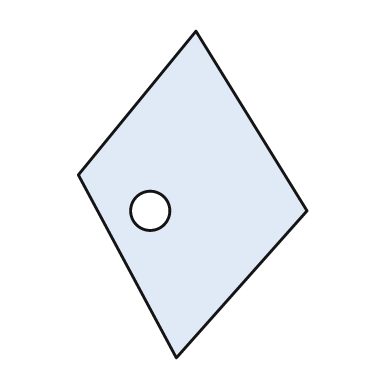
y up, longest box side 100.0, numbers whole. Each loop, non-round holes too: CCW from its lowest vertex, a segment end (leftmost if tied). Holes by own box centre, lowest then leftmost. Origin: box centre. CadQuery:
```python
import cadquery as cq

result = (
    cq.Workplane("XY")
    .moveTo(-5.0, -50.0)
    .lineTo(35.0, -5.0)
    .lineTo(1.0, 50.0)
    .lineTo(-35.0, 6.0)
    .close()
    .moveTo(-13.0, -5.0)
    .circle(6.0)
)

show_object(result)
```